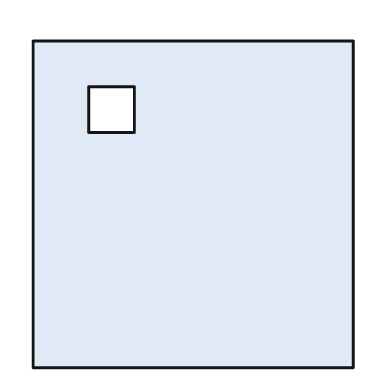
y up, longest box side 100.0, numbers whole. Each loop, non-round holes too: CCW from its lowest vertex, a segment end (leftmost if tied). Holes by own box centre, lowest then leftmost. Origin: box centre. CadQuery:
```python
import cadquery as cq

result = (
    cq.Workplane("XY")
    .moveTo(-49.0, -50.0)
    .lineTo(49.0, -50.0)
    .lineTo(49.0, 50.0)
    .lineTo(-49.0, 50.0)
    .close()
    .moveTo(-32.0, 22.0)
    .lineTo(-18.0, 22.0)
    .lineTo(-18.0, 36.0)
    .lineTo(-32.0, 36.0)
    .close()
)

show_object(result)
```